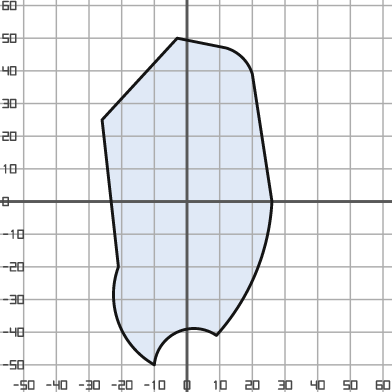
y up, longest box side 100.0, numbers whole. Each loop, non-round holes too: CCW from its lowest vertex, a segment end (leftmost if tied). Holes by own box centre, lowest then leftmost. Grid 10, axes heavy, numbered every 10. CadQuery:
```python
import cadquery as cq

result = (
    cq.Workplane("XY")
    .moveTo(-10.0, -50.0)
    .threePointArc((-3.0, -40.0), (9.0, -41.0))
    .threePointArc((21.0, -22.0), (26.0, 0.0))
    .lineTo(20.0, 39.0)
    .threePointArc((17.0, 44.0), (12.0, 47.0))
    .lineTo(-3.0, 50.0)
    .lineTo(-26.0, 25.0)
    .lineTo(-21.0, -20.0)
    .threePointArc((-21.0, -37.0), (-10.0, -50.0))
    .close()
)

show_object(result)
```